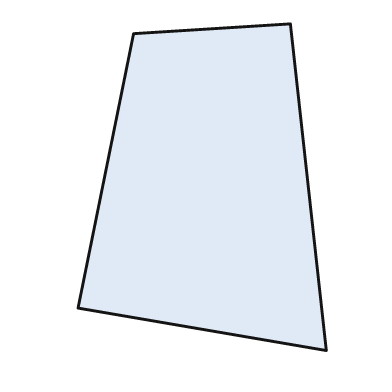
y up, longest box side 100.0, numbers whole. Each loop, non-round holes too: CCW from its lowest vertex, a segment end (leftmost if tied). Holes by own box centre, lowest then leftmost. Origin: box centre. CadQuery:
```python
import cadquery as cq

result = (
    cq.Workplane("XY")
    .moveTo(38.0, -50.0)
    .lineTo(27.0, 50.0)
    .lineTo(-21.0, 47.0)
    .lineTo(-38.0, -37.0)
    .close()
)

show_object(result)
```